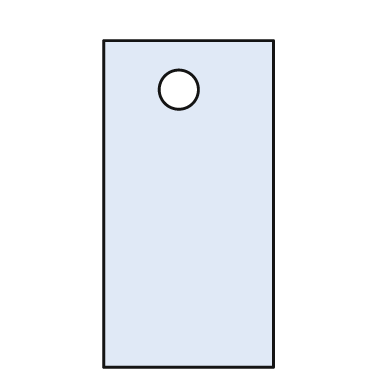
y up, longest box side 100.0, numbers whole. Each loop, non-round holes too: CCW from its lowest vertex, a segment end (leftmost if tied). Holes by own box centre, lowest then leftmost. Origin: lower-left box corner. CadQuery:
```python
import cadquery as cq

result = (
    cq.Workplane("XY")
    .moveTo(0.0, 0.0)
    .lineTo(52.0, 0.0)
    .lineTo(52.0, 100.0)
    .lineTo(0.0, 100.0)
    .close()
    .moveTo(23.0, 85.0)
    .circle(6.0)
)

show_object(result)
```